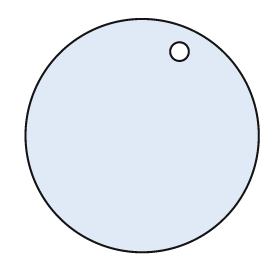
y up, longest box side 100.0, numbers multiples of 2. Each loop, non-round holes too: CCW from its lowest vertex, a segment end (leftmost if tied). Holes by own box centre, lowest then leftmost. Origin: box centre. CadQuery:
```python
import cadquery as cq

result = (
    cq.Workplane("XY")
    .moveTo(0.0, 0.0)
    .circle(50.0)
    .moveTo(16.0, 36.0)
    .circle(4.0)
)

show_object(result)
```